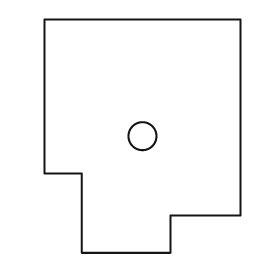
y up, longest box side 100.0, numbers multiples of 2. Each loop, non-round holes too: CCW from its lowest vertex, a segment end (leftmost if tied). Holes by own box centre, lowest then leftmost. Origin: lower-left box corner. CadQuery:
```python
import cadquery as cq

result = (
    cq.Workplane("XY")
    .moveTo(16.0, 0.0)
    .lineTo(54.0, 0.0)
    .lineTo(54.0, 16.0)
    .lineTo(84.0, 16.0)
    .lineTo(84.0, 100.0)
    .lineTo(0.0, 100.0)
    .lineTo(0.0, 34.0)
    .lineTo(16.0, 34.0)
    .close()
    .moveTo(42.0, 50.0)
    .circle(6.0)
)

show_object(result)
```